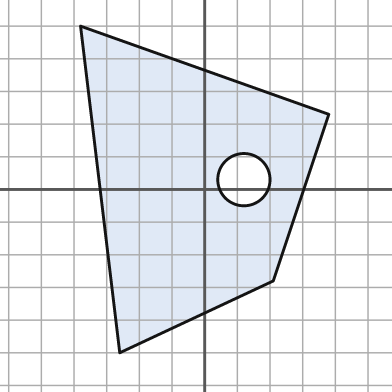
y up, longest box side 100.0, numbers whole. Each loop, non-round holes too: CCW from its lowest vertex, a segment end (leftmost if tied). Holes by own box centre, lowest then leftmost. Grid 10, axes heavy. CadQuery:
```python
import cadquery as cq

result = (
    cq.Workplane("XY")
    .moveTo(-26.0, -50.0)
    .lineTo(21.0, -28.0)
    .lineTo(38.0, 23.0)
    .lineTo(-38.0, 50.0)
    .close()
    .moveTo(12.0, 3.0)
    .circle(8.0)
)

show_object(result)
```